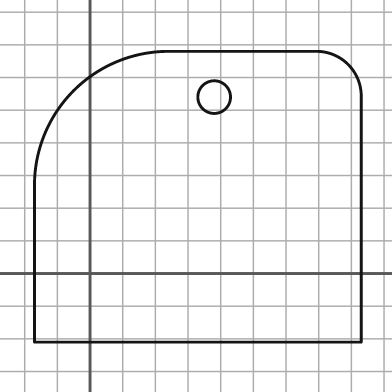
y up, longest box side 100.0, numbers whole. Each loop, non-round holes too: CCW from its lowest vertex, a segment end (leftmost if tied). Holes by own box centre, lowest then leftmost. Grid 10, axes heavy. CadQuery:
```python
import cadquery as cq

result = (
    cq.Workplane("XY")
    .moveTo(-17.0, -21.0)
    .lineTo(83.0, -21.0)
    .lineTo(83.0, 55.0)
    .threePointArc((79.0, 64.0), (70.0, 68.0))
    .lineTo(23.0, 68.0)
    .threePointArc((-5.0, 56.0), (-17.0, 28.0))
    .close()
    .moveTo(38.0, 54.0)
    .circle(5.0)
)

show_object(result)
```